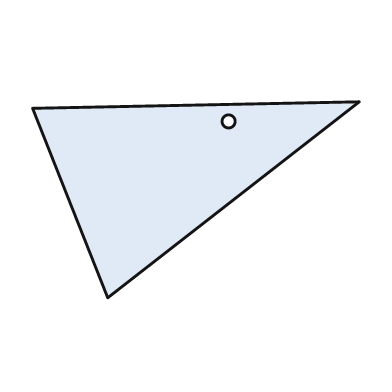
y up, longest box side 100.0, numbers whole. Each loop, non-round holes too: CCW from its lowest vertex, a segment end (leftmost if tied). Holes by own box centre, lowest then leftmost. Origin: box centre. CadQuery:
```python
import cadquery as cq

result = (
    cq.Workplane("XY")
    .moveTo(-27.0, -30.0)
    .lineTo(50.0, 30.0)
    .lineTo(-50.0, 28.0)
    .close()
    .moveTo(10.0, 24.0)
    .circle(2.0)
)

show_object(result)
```